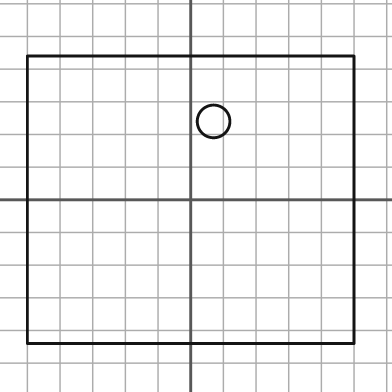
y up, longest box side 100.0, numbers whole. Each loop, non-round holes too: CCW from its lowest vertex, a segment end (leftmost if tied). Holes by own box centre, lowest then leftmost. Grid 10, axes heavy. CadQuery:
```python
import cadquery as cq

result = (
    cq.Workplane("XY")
    .moveTo(-50.0, -44.0)
    .lineTo(50.0, -44.0)
    .lineTo(50.0, 44.0)
    .lineTo(-50.0, 44.0)
    .close()
    .moveTo(7.0, 24.0)
    .circle(5.0)
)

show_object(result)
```